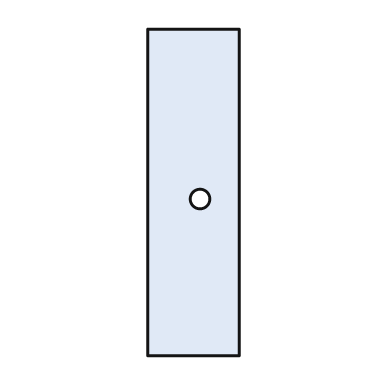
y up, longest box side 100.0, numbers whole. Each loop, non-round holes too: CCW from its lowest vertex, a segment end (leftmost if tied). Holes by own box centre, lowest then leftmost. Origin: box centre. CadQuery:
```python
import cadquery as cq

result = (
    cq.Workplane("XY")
    .moveTo(-14.0, -50.0)
    .lineTo(14.0, -50.0)
    .lineTo(14.0, 50.0)
    .lineTo(-14.0, 50.0)
    .close()
    .moveTo(2.0, -2.0)
    .circle(3.0)
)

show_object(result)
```